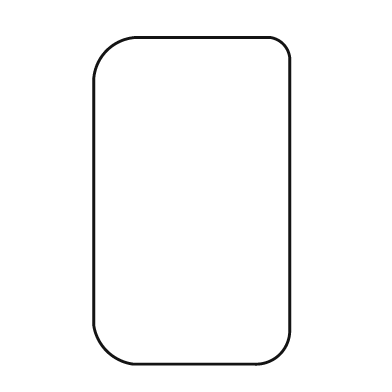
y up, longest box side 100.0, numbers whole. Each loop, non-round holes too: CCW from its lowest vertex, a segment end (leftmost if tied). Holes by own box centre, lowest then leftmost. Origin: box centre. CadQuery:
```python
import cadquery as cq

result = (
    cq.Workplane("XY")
    .moveTo(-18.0, -50.0)
    .lineTo(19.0, -50.0)
    .threePointArc((27.0, -47.0), (30.0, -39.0))
    .lineTo(30.0, 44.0)
    .threePointArc((28.0, 48.0), (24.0, 50.0))
    .lineTo(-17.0, 50.0)
    .threePointArc((-26.0, 46.0), (-30.0, 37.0))
    .lineTo(-30.0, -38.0)
    .threePointArc((-26.0, -46.0), (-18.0, -50.0))
    .close()
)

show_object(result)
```